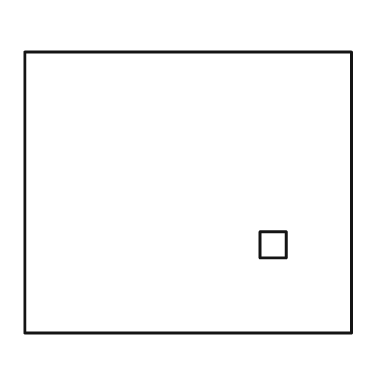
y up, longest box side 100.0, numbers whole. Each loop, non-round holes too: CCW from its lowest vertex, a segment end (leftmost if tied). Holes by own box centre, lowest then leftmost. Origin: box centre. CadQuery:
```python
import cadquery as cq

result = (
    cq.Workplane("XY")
    .moveTo(-50.0, -43.0)
    .lineTo(50.0, -43.0)
    .lineTo(50.0, 43.0)
    .lineTo(-50.0, 43.0)
    .close()
    .moveTo(22.0, -20.0)
    .lineTo(30.0, -20.0)
    .lineTo(30.0, -12.0)
    .lineTo(22.0, -12.0)
    .close()
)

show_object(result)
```